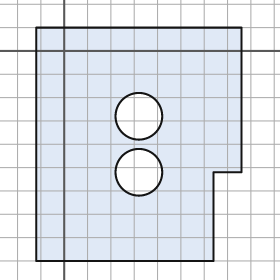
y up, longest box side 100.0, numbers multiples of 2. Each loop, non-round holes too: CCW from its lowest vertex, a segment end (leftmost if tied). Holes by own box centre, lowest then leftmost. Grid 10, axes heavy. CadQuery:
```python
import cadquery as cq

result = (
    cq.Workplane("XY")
    .moveTo(-12.0, -90.0)
    .lineTo(64.0, -90.0)
    .lineTo(64.0, -52.0)
    .lineTo(76.0, -52.0)
    .lineTo(76.0, 10.0)
    .lineTo(-12.0, 10.0)
    .close()
    .moveTo(32.0, -52.0)
    .circle(10.0)
    .moveTo(32.0, -28.0)
    .circle(10.0)
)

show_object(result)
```